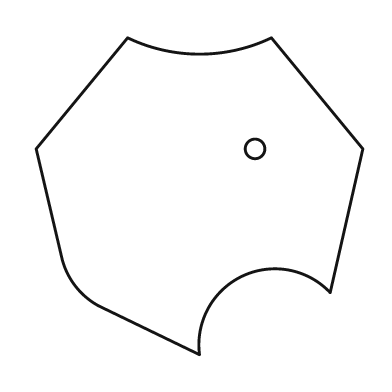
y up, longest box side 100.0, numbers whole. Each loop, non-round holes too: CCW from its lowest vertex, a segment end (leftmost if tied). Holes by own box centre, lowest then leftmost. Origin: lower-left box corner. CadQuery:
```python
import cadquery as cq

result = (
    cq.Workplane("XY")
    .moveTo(50.0, 0.0)
    .threePointArc((63.0, 24.0), (90.0, 19.0))
    .lineTo(100.0, 63.0)
    .lineTo(72.0, 97.0)
    .threePointArc((50.0, 92.0), (28.0, 97.0))
    .lineTo(0.0, 63.0)
    .lineTo(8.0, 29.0)
    .threePointArc((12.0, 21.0), (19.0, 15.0))
    .close()
    .moveTo(67.0, 63.0)
    .circle(3.0)
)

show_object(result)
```